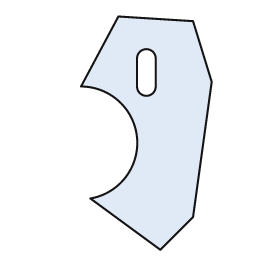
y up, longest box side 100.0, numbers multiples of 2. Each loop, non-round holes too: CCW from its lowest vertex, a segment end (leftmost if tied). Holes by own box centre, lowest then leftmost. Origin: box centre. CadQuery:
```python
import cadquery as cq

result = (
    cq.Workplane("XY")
    .moveTo(6.0, -50.0)
    .lineTo(20.0, -36.0)
    .lineTo(28.0, 22.0)
    .lineTo(20.0, 48.0)
    .lineTo(-12.0, 50.0)
    .lineTo(-28.0, 20.0)
    .threePointArc((-4.0, -2.0), (-24.0, -28.0))
    .close()
    .moveTo(-4.0, 20.0)
    .threePointArc((0.0, 16.0), (4.0, 20.0))
    .lineTo(4.0, 32.0)
    .threePointArc((0.0, 36.0), (-4.0, 32.0))
    .close()
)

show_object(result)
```